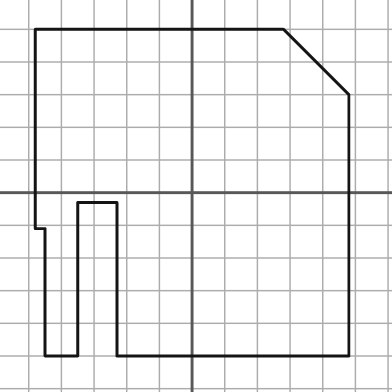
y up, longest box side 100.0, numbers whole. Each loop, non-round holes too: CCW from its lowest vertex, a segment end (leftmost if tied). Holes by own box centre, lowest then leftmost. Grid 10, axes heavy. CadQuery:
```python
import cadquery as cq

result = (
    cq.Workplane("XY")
    .moveTo(-45.0, -50.0)
    .lineTo(-35.0, -50.0)
    .lineTo(-35.0, -3.0)
    .lineTo(-23.0, -3.0)
    .lineTo(-23.0, -50.0)
    .lineTo(48.0, -50.0)
    .lineTo(48.0, 30.0)
    .lineTo(28.0, 50.0)
    .lineTo(-48.0, 50.0)
    .lineTo(-48.0, -11.0)
    .lineTo(-45.0, -11.0)
    .close()
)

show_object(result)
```